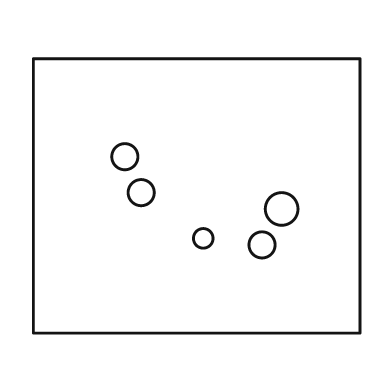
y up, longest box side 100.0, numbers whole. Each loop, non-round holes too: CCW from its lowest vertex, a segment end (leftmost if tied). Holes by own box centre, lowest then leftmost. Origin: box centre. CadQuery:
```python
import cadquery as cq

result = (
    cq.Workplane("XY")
    .moveTo(-50.0, -42.0)
    .lineTo(50.0, -42.0)
    .lineTo(50.0, 42.0)
    .lineTo(-50.0, 42.0)
    .close()
    .moveTo(20.0, -15.0)
    .circle(4.0)
    .moveTo(2.0, -13.0)
    .circle(3.0)
    .moveTo(26.0, -4.0)
    .circle(5.0)
    .moveTo(-17.0, 1.0)
    .circle(4.0)
    .moveTo(-22.0, 12.0)
    .circle(4.0)
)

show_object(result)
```